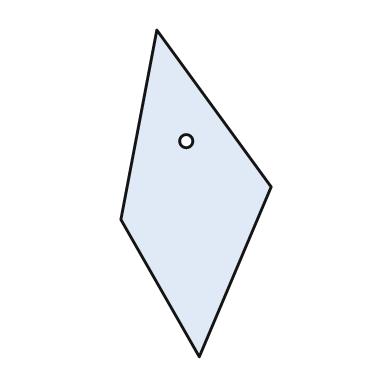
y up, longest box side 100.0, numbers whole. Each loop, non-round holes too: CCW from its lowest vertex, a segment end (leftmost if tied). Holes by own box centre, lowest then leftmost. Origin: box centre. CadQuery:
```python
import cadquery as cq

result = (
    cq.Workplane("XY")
    .moveTo(1.0, -50.0)
    .lineTo(23.0, 2.0)
    .lineTo(-12.0, 50.0)
    .lineTo(-23.0, -8.0)
    .close()
    .moveTo(-3.0, 16.0)
    .circle(2.0)
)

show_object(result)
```